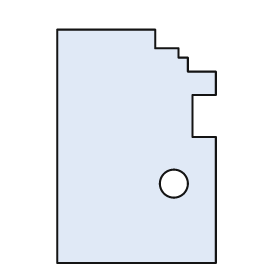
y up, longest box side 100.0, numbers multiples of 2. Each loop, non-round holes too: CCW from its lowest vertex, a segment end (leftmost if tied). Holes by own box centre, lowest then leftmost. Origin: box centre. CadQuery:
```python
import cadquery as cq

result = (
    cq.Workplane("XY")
    .moveTo(-34.0, -50.0)
    .lineTo(34.0, -50.0)
    .lineTo(34.0, 4.0)
    .lineTo(24.0, 4.0)
    .lineTo(24.0, 22.0)
    .lineTo(34.0, 22.0)
    .lineTo(34.0, 32.0)
    .lineTo(22.0, 32.0)
    .lineTo(22.0, 38.0)
    .lineTo(18.0, 38.0)
    .lineTo(18.0, 42.0)
    .lineTo(8.0, 42.0)
    .lineTo(8.0, 50.0)
    .lineTo(-34.0, 50.0)
    .close()
    .moveTo(16.0, -16.0)
    .circle(6.0)
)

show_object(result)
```